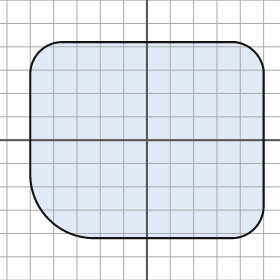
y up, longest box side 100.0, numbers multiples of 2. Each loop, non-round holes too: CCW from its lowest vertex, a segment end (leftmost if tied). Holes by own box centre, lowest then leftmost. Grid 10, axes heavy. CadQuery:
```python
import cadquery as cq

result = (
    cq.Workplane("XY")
    .moveTo(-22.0, -42.0)
    .lineTo(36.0, -42.0)
    .threePointArc((46.0, -38.0), (50.0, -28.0))
    .lineTo(50.0, 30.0)
    .threePointArc((46.0, 38.0), (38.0, 42.0))
    .lineTo(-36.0, 42.0)
    .threePointArc((-46.0, 38.0), (-50.0, 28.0))
    .lineTo(-50.0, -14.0)
    .threePointArc((-42.0, -34.0), (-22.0, -42.0))
    .close()
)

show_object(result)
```